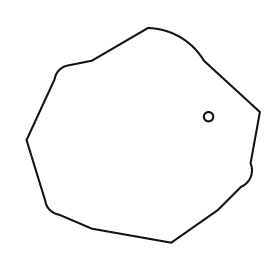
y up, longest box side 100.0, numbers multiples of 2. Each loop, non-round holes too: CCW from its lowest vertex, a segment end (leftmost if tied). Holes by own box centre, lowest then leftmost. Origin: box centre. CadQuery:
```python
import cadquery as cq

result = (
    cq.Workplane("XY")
    .moveTo(12.0, -46.0)
    .lineTo(32.0, -32.0)
    .lineTo(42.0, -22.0)
    .threePointArc((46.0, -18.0), (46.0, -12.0))
    .lineTo(50.0, 10.0)
    .lineTo(26.0, 32.0)
    .threePointArc((16.0, 42.0), (2.0, 46.0))
    .lineTo(-22.0, 32.0)
    .lineTo(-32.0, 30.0)
    .threePointArc((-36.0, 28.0), (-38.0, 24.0))
    .lineTo(-50.0, -2.0)
    .lineTo(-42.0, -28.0)
    .threePointArc((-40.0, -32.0), (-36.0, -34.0))
    .lineTo(-22.0, -40.0)
    .close()
    .moveTo(28.0, 8.0)
    .circle(2.0)
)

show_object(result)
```